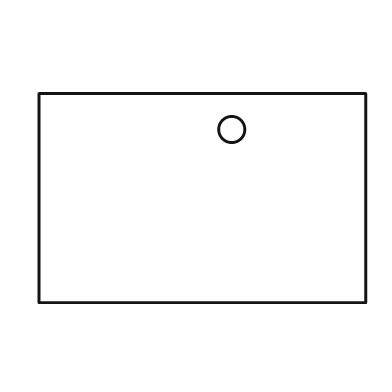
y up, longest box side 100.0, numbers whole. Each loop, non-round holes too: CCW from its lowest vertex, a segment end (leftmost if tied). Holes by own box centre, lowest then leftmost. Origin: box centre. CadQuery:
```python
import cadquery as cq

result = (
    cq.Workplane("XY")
    .moveTo(-50.0, -32.0)
    .lineTo(50.0, -32.0)
    .lineTo(50.0, 32.0)
    .lineTo(-50.0, 32.0)
    .close()
    .moveTo(9.0, 21.0)
    .circle(4.0)
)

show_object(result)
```